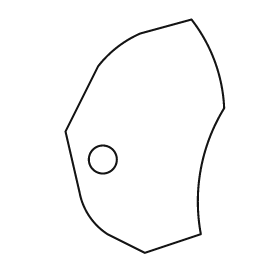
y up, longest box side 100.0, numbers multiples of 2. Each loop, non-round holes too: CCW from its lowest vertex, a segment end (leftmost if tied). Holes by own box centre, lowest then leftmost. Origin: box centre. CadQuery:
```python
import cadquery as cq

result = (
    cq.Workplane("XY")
    .moveTo(0.0, -50.0)
    .lineTo(24.0, -42.0)
    .threePointArc((24.0, -14.0), (34.0, 12.0))
    .threePointArc((30.0, 32.0), (20.0, 50.0))
    .lineTo(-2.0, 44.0)
    .threePointArc((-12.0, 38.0), (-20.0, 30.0))
    .lineTo(-34.0, 2.0)
    .lineTo(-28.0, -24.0)
    .threePointArc((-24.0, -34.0), (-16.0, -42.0))
    .close()
    .moveTo(-18.0, -10.0)
    .circle(6.0)
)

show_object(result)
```